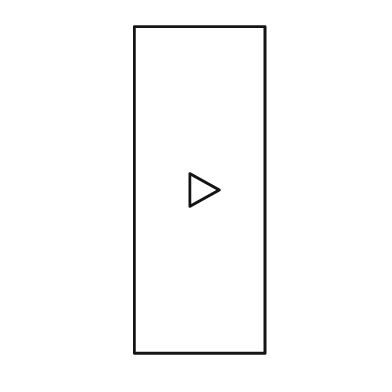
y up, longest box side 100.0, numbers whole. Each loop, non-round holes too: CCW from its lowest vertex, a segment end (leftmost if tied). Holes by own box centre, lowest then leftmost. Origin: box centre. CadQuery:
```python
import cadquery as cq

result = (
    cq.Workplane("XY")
    .moveTo(-20.0, -50.0)
    .lineTo(20.0, -50.0)
    .lineTo(20.0, 50.0)
    .lineTo(-20.0, 50.0)
    .close()
    .moveTo(-3.0, -5.0)
    .lineTo(6.0, 0.0)
    .lineTo(-3.0, 5.0)
    .close()
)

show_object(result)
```